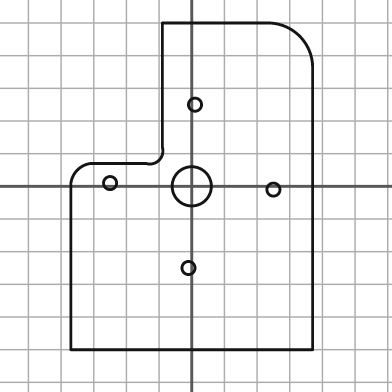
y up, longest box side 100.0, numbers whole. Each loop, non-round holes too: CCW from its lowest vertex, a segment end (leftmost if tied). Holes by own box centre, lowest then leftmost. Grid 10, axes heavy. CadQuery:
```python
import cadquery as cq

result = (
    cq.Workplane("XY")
    .moveTo(-37.0, -50.0)
    .lineTo(37.0, -50.0)
    .lineTo(37.0, 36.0)
    .threePointArc((33.0, 46.0), (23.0, 50.0))
    .lineTo(-9.0, 50.0)
    .lineTo(-9.0, 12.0)
    .threePointArc((-10.0, 8.0), (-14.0, 7.0))
    .lineTo(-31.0, 7.0)
    .threePointArc((-35.0, 5.0), (-37.0, 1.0))
    .close()
    .moveTo(-1.0, -25.0)
    .circle(2.0)
    .moveTo(25.0, -1.0)
    .circle(2.0)
    .moveTo(0.0, 0.0)
    .circle(6.0)
    .moveTo(-25.0, 1.0)
    .circle(2.0)
    .moveTo(1.0, 25.0)
    .circle(2.0)
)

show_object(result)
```